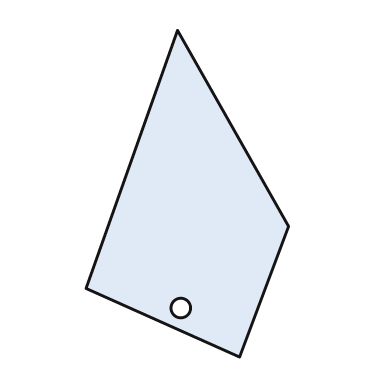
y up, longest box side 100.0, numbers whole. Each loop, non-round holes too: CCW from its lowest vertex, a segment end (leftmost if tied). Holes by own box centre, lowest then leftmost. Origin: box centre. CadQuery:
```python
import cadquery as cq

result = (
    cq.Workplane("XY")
    .moveTo(16.0, -50.0)
    .lineTo(31.0, -10.0)
    .lineTo(-3.0, 50.0)
    .lineTo(-31.0, -29.0)
    .close()
    .moveTo(-2.0, -35.0)
    .circle(3.0)
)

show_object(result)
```